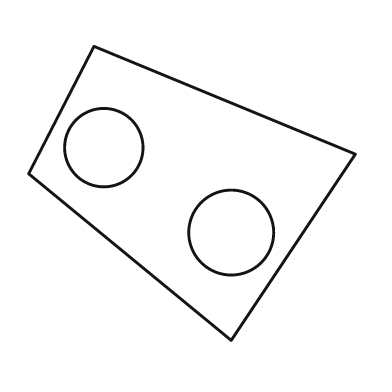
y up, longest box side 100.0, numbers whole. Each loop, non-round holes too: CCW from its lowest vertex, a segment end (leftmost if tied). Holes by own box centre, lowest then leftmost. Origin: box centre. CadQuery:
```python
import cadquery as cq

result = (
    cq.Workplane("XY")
    .moveTo(12.0, -45.0)
    .lineTo(50.0, 12.0)
    .lineTo(-30.0, 45.0)
    .lineTo(-50.0, 6.0)
    .close()
    .moveTo(12.0, -12.0)
    .circle(13.0)
    .moveTo(-27.0, 14.0)
    .circle(12.0)
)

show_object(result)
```